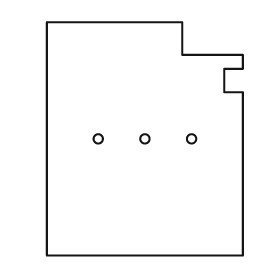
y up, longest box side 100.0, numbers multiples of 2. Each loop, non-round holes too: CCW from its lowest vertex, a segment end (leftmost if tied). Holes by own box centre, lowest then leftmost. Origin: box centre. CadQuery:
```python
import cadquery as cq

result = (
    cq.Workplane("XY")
    .moveTo(-42.0, -50.0)
    .lineTo(42.0, -50.0)
    .lineTo(42.0, 20.0)
    .lineTo(34.0, 20.0)
    .lineTo(34.0, 30.0)
    .lineTo(42.0, 30.0)
    .lineTo(42.0, 36.0)
    .lineTo(16.0, 36.0)
    .lineTo(16.0, 50.0)
    .lineTo(-42.0, 50.0)
    .close()
    .moveTo(-20.0, 0.0)
    .circle(2.0)
    .moveTo(0.0, 0.0)
    .circle(2.0)
    .moveTo(20.0, 0.0)
    .circle(2.0)
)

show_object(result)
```